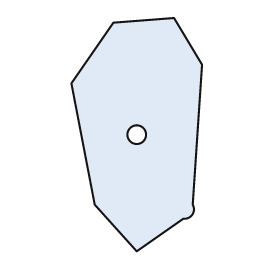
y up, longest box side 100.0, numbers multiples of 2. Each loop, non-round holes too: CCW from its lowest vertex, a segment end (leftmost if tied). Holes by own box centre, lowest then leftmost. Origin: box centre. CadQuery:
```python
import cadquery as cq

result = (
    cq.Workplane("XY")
    .moveTo(0.0, -50.0)
    .lineTo(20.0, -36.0)
    .threePointArc((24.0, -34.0), (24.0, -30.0))
    .lineTo(28.0, 30.0)
    .lineTo(16.0, 50.0)
    .lineTo(-10.0, 48.0)
    .lineTo(-28.0, 22.0)
    .lineTo(-18.0, -30.0)
    .close()
    .moveTo(0.0, 0.0)
    .circle(4.0)
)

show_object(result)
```